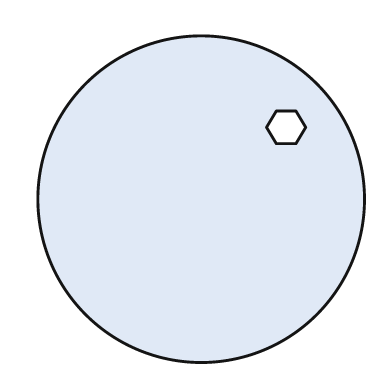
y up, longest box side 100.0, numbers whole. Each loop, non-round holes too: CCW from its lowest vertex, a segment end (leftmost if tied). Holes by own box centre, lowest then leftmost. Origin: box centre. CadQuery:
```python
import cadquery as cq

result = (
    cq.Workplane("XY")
    .moveTo(0.0, 0.0)
    .circle(50.0)
    .moveTo(23.0, 17.0)
    .lineTo(29.0, 17.0)
    .lineTo(32.0, 22.0)
    .lineTo(29.0, 27.0)
    .lineTo(23.0, 27.0)
    .lineTo(20.0, 22.0)
    .close()
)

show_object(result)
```